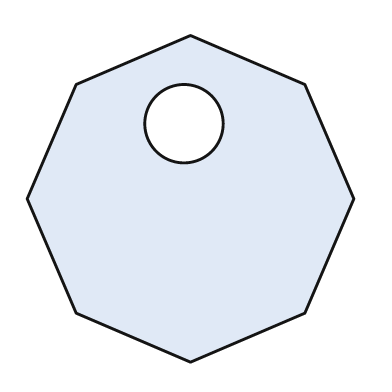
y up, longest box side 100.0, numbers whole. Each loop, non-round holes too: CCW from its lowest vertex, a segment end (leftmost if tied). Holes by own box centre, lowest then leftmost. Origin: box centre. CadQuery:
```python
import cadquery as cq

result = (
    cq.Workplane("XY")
    .moveTo(0.0, -50.0)
    .lineTo(35.0, -35.0)
    .lineTo(50.0, 0.0)
    .lineTo(35.0, 35.0)
    .lineTo(0.0, 50.0)
    .lineTo(-35.0, 35.0)
    .lineTo(-50.0, 0.0)
    .lineTo(-35.0, -35.0)
    .close()
    .moveTo(-2.0, 23.0)
    .circle(12.0)
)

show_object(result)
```